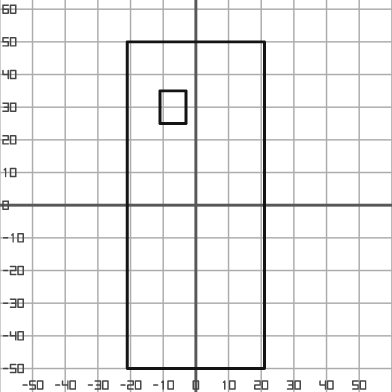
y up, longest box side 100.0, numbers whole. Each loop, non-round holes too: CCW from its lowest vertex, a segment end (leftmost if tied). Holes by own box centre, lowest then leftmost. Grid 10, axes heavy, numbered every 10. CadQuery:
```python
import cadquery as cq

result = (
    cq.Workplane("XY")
    .moveTo(-21.0, -50.0)
    .lineTo(21.0, -50.0)
    .lineTo(21.0, 50.0)
    .lineTo(-21.0, 50.0)
    .close()
    .moveTo(-11.0, 25.0)
    .lineTo(-3.0, 25.0)
    .lineTo(-3.0, 35.0)
    .lineTo(-11.0, 35.0)
    .close()
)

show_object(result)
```